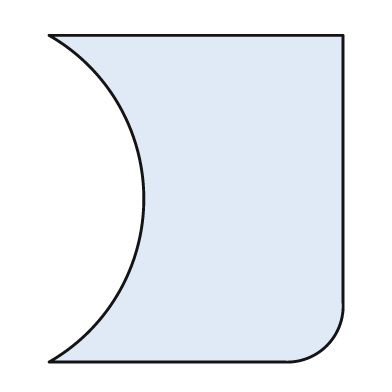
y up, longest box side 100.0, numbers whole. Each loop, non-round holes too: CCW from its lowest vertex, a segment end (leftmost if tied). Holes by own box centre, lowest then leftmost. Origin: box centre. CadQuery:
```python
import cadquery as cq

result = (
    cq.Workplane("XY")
    .moveTo(-45.0, -50.0)
    .lineTo(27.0, -50.0)
    .threePointArc((40.0, -45.0), (45.0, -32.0))
    .lineTo(45.0, 50.0)
    .lineTo(-45.0, 50.0)
    .threePointArc((-16.0, 0.0), (-45.0, -50.0))
    .close()
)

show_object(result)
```